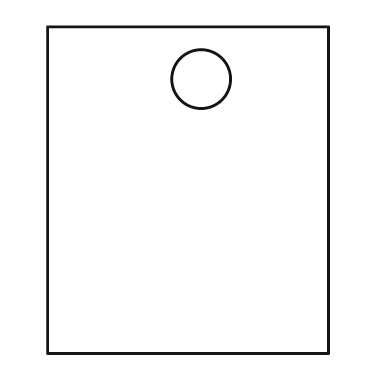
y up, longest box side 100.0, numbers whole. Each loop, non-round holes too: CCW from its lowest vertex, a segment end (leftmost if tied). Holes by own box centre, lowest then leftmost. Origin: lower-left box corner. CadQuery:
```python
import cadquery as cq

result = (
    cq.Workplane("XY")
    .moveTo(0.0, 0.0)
    .lineTo(86.0, 0.0)
    .lineTo(86.0, 100.0)
    .lineTo(0.0, 100.0)
    .close()
    .moveTo(47.0, 84.0)
    .circle(9.0)
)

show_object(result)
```